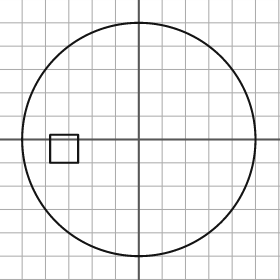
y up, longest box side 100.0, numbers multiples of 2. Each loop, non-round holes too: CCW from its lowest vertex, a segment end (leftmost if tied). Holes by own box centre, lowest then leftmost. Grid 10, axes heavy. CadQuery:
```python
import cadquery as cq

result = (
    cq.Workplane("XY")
    .moveTo(0.0, 0.0)
    .circle(50.0)
    .moveTo(-38.0, -10.0)
    .lineTo(-26.0, -10.0)
    .lineTo(-26.0, 2.0)
    .lineTo(-38.0, 2.0)
    .close()
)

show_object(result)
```